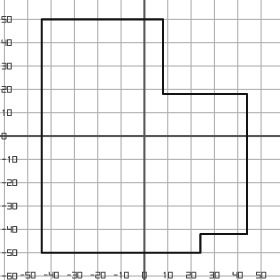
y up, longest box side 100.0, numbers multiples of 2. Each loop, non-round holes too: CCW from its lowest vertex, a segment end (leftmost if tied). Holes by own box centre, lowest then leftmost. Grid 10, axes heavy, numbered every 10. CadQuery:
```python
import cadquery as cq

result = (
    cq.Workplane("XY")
    .moveTo(-44.0, -50.0)
    .lineTo(24.0, -50.0)
    .lineTo(24.0, -42.0)
    .lineTo(44.0, -42.0)
    .lineTo(44.0, 18.0)
    .lineTo(8.0, 18.0)
    .lineTo(8.0, 50.0)
    .lineTo(-44.0, 50.0)
    .close()
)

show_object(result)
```